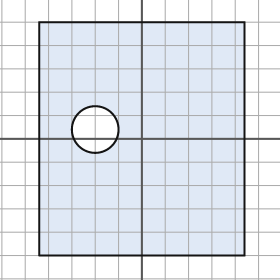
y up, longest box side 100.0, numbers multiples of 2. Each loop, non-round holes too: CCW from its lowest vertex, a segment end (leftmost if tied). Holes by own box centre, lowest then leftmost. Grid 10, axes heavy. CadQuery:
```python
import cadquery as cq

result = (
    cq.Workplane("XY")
    .moveTo(-44.0, -50.0)
    .lineTo(44.0, -50.0)
    .lineTo(44.0, 50.0)
    .lineTo(-44.0, 50.0)
    .close()
    .moveTo(-20.0, 4.0)
    .circle(10.0)
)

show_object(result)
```